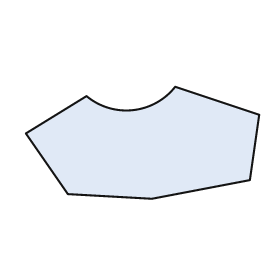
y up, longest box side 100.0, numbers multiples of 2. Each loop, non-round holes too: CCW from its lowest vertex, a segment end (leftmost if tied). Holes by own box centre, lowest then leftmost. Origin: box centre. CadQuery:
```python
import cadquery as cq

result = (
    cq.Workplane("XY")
    .moveTo(4.0, -24.0)
    .lineTo(46.0, -16.0)
    .lineTo(50.0, 12.0)
    .lineTo(14.0, 24.0)
    .threePointArc((-4.0, 14.0), (-24.0, 20.0))
    .lineTo(-50.0, 4.0)
    .lineTo(-32.0, -22.0)
    .close()
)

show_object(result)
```